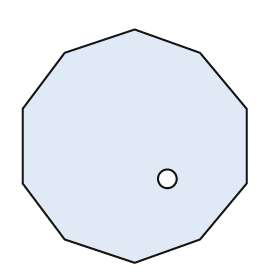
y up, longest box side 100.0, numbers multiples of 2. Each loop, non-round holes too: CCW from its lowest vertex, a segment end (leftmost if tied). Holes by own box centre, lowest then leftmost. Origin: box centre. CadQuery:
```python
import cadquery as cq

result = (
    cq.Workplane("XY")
    .moveTo(0.0, -50.0)
    .lineTo(28.0, -40.0)
    .lineTo(48.0, -16.0)
    .lineTo(48.0, 16.0)
    .lineTo(28.0, 40.0)
    .lineTo(0.0, 50.0)
    .lineTo(-30.0, 40.0)
    .lineTo(-48.0, 16.0)
    .lineTo(-48.0, -16.0)
    .lineTo(-30.0, -40.0)
    .close()
    .moveTo(14.0, -14.0)
    .circle(4.0)
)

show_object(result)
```